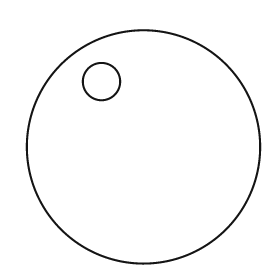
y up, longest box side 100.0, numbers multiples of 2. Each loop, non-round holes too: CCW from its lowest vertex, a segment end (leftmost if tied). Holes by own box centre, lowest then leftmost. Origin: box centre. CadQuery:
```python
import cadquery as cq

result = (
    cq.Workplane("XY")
    .moveTo(0.0, 0.0)
    .circle(50.0)
    .moveTo(-18.0, 28.0)
    .circle(8.0)
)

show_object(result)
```